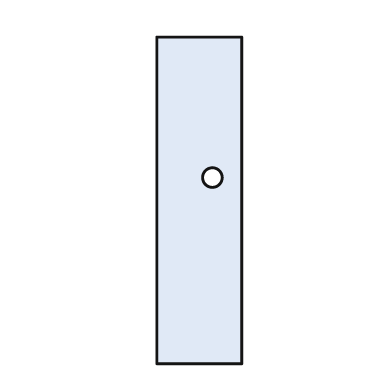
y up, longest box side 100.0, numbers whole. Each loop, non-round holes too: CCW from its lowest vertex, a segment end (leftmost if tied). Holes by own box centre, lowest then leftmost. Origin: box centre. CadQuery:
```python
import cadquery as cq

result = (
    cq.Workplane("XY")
    .moveTo(-13.0, -50.0)
    .lineTo(13.0, -50.0)
    .lineTo(13.0, 50.0)
    .lineTo(-13.0, 50.0)
    .close()
    .moveTo(4.0, 7.0)
    .circle(3.0)
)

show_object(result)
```